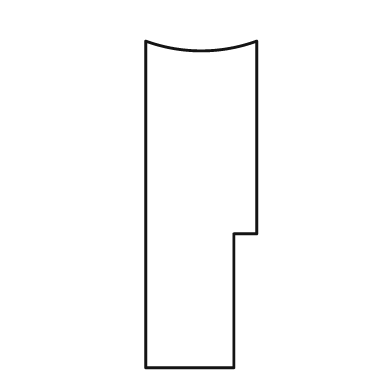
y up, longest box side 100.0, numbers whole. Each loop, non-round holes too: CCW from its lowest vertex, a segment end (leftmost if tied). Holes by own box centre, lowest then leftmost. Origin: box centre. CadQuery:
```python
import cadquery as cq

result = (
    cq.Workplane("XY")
    .moveTo(-17.0, -50.0)
    .lineTo(10.0, -50.0)
    .lineTo(10.0, -9.0)
    .lineTo(17.0, -9.0)
    .lineTo(17.0, 50.0)
    .threePointArc((0.0, 47.0), (-17.0, 50.0))
    .close()
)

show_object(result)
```